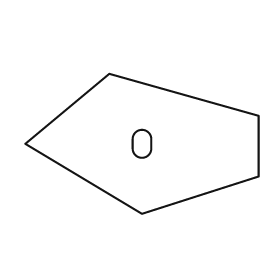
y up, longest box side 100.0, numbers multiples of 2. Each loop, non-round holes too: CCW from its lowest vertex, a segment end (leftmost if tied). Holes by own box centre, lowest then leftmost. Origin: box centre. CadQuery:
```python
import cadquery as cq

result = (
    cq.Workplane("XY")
    .moveTo(0.0, -30.0)
    .lineTo(50.0, -14.0)
    .lineTo(50.0, 12.0)
    .lineTo(-14.0, 30.0)
    .lineTo(-50.0, 0.0)
    .close()
    .moveTo(-4.0, -2.0)
    .threePointArc((0.0, -6.0), (4.0, -2.0))
    .lineTo(4.0, 2.0)
    .threePointArc((0.0, 6.0), (-4.0, 2.0))
    .close()
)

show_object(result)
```